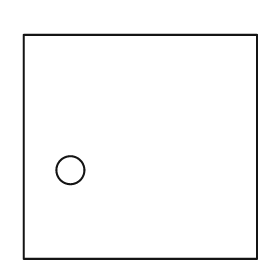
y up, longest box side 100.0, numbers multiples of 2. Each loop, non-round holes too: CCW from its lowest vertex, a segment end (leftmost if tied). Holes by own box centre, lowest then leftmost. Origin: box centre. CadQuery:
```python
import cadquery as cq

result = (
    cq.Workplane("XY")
    .moveTo(-50.0, -48.0)
    .lineTo(50.0, -48.0)
    .lineTo(50.0, 48.0)
    .lineTo(-50.0, 48.0)
    .close()
    .moveTo(-30.0, -10.0)
    .circle(6.0)
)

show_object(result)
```